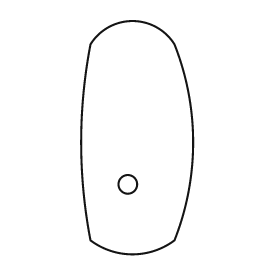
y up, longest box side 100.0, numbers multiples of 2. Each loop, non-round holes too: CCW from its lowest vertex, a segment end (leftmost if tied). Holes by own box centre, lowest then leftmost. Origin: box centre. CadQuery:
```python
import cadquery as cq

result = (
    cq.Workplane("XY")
    .moveTo(-20.0, -44.0)
    .threePointArc((-2.0, -50.0), (16.0, -44.0))
    .threePointArc((24.0, -2.0), (16.0, 40.0))
    .threePointArc((-2.0, 50.0), (-20.0, 40.0))
    .threePointArc((-24.0, -2.0), (-20.0, -44.0))
    .close()
    .moveTo(-4.0, -20.0)
    .circle(4.0)
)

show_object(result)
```